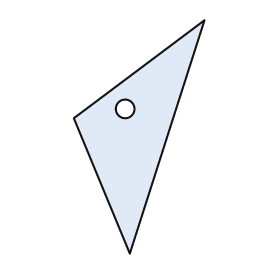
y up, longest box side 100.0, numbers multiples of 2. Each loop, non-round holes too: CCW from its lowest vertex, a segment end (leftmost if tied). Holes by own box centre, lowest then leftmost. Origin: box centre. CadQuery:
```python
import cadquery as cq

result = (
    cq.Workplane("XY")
    .moveTo(-4.0, -50.0)
    .lineTo(28.0, 50.0)
    .lineTo(-28.0, 8.0)
    .close()
    .moveTo(-6.0, 12.0)
    .circle(4.0)
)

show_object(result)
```